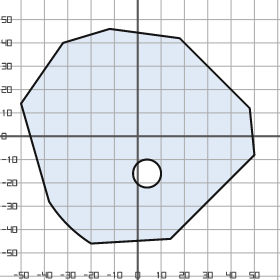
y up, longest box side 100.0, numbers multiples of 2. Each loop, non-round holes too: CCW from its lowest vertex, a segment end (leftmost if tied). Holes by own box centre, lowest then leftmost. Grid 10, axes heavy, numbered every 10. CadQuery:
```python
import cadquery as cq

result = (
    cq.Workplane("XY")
    .moveTo(-20.0, -46.0)
    .lineTo(14.0, -44.0)
    .lineTo(50.0, -8.0)
    .lineTo(48.0, 12.0)
    .lineTo(18.0, 42.0)
    .lineTo(-12.0, 46.0)
    .lineTo(-32.0, 40.0)
    .lineTo(-50.0, 14.0)
    .lineTo(-38.0, -28.0)
    .threePointArc((-30.0, -38.0), (-20.0, -46.0))
    .close()
    .moveTo(4.0, -16.0)
    .circle(6.0)
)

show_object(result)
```